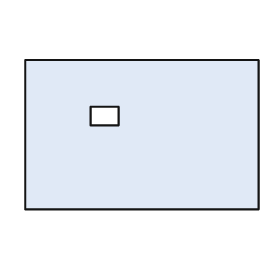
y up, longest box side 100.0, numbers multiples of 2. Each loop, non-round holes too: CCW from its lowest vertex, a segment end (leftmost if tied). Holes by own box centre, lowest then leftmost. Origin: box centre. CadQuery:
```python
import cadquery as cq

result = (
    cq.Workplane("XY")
    .moveTo(-50.0, -32.0)
    .lineTo(50.0, -32.0)
    .lineTo(50.0, 32.0)
    .lineTo(-50.0, 32.0)
    .close()
    .moveTo(-22.0, 4.0)
    .lineTo(-10.0, 4.0)
    .lineTo(-10.0, 12.0)
    .lineTo(-22.0, 12.0)
    .close()
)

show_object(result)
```